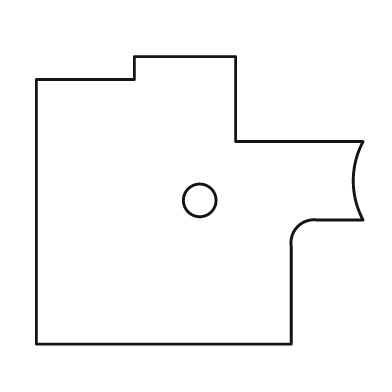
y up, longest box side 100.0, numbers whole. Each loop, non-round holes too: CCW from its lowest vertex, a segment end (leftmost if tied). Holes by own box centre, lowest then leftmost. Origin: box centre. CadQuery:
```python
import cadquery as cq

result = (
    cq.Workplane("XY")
    .moveTo(-50.0, -44.0)
    .lineTo(28.0, -44.0)
    .lineTo(28.0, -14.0)
    .threePointArc((30.0, -8.0), (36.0, -6.0))
    .lineTo(50.0, -6.0)
    .threePointArc((47.0, 6.0), (50.0, 18.0))
    .lineTo(11.0, 18.0)
    .lineTo(11.0, 44.0)
    .lineTo(-20.0, 44.0)
    .lineTo(-20.0, 37.0)
    .lineTo(-50.0, 37.0)
    .close()
    .moveTo(0.0, 0.0)
    .circle(5.0)
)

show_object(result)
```